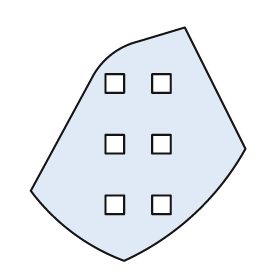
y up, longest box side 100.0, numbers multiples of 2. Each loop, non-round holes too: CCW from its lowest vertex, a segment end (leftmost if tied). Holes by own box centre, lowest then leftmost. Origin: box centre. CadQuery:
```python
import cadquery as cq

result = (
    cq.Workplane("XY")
    .moveTo(-6.0, -50.0)
    .threePointArc((24.0, -30.0), (46.0, -2.0))
    .lineTo(20.0, 50.0)
    .lineTo(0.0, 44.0)
    .threePointArc((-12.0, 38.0), (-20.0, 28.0))
    .lineTo(-46.0, -20.0)
    .threePointArc((-28.0, -38.0), (-6.0, -50.0))
    .close()
    .moveTo(-14.0, -30.0)
    .lineTo(-6.0, -30.0)
    .lineTo(-6.0, -22.0)
    .lineTo(-14.0, -22.0)
    .close()
    .moveTo(6.0, -30.0)
    .lineTo(14.0, -30.0)
    .lineTo(14.0, -22.0)
    .lineTo(6.0, -22.0)
    .close()
    .moveTo(-14.0, -4.0)
    .lineTo(-6.0, -4.0)
    .lineTo(-6.0, 4.0)
    .lineTo(-14.0, 4.0)
    .close()
    .moveTo(6.0, -4.0)
    .lineTo(14.0, -4.0)
    .lineTo(14.0, 4.0)
    .lineTo(6.0, 4.0)
    .close()
    .moveTo(-14.0, 22.0)
    .lineTo(-6.0, 22.0)
    .lineTo(-6.0, 30.0)
    .lineTo(-14.0, 30.0)
    .close()
    .moveTo(6.0, 22.0)
    .lineTo(14.0, 22.0)
    .lineTo(14.0, 30.0)
    .lineTo(6.0, 30.0)
    .close()
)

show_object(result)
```